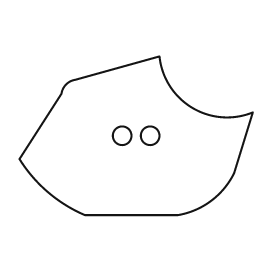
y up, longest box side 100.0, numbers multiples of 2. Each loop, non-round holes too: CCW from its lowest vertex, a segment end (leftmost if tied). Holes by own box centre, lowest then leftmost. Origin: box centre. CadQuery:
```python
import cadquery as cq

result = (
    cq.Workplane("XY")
    .moveTo(-22.0, -34.0)
    .lineTo(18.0, -34.0)
    .threePointArc((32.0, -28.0), (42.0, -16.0))
    .lineTo(50.0, 10.0)
    .threePointArc((24.0, 12.0), (10.0, 34.0))
    .lineTo(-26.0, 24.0)
    .threePointArc((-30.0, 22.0), (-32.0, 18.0))
    .lineTo(-50.0, -10.0)
    .threePointArc((-38.0, -24.0), (-22.0, -34.0))
    .close()
    .moveTo(-6.0, 0.0)
    .circle(4.0)
    .moveTo(6.0, 0.0)
    .circle(4.0)
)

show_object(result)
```